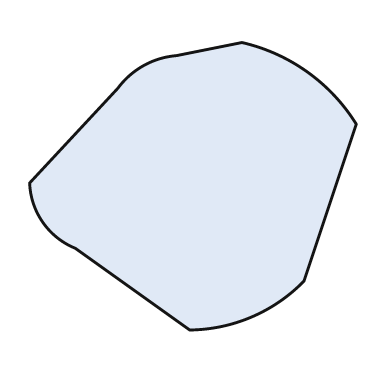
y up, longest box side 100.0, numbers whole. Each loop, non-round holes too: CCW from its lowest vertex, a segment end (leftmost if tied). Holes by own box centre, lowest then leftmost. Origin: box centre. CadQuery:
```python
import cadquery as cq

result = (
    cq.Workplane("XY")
    .moveTo(-1.0, -44.0)
    .threePointArc((18.0, -40.0), (34.0, -29.0))
    .lineTo(50.0, 19.0)
    .threePointArc((35.0, 35.0), (15.0, 44.0))
    .lineTo(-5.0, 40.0)
    .threePointArc((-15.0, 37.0), (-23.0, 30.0))
    .lineTo(-50.0, 1.0)
    .threePointArc((-46.0, -11.0), (-36.0, -19.0))
    .close()
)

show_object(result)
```